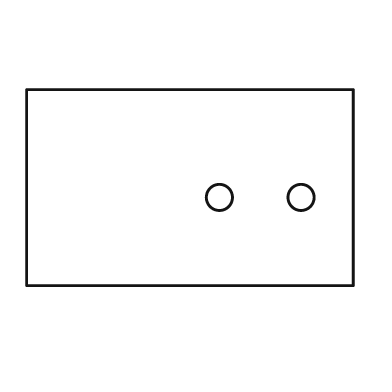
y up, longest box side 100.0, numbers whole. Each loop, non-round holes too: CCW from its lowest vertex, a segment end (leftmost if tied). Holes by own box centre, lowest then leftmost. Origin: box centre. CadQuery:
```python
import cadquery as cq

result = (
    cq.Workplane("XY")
    .moveTo(-50.0, -30.0)
    .lineTo(50.0, -30.0)
    .lineTo(50.0, 30.0)
    .lineTo(-50.0, 30.0)
    .close()
    .moveTo(9.0, -3.0)
    .circle(4.0)
    .moveTo(34.0, -3.0)
    .circle(4.0)
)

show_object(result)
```